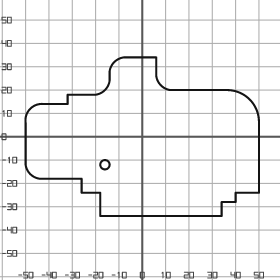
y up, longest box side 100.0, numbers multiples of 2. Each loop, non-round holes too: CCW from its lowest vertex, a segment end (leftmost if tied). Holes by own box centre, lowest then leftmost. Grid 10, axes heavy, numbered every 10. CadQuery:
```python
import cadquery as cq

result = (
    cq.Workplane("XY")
    .moveTo(-18.0, -34.0)
    .lineTo(34.0, -34.0)
    .lineTo(34.0, -28.0)
    .lineTo(40.0, -28.0)
    .lineTo(40.0, -24.0)
    .lineTo(50.0, -24.0)
    .lineTo(50.0, 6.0)
    .threePointArc((46.0, 16.0), (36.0, 20.0))
    .lineTo(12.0, 20.0)
    .threePointArc((8.0, 22.0), (6.0, 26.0))
    .lineTo(6.0, 34.0)
    .lineTo(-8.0, 34.0)
    .threePointArc((-12.0, 32.0), (-14.0, 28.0))
    .lineTo(-14.0, 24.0)
    .threePointArc((-16.0, 20.0), (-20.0, 18.0))
    .lineTo(-32.0, 18.0)
    .lineTo(-32.0, 14.0)
    .lineTo(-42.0, 14.0)
    .threePointArc((-48.0, 12.0), (-50.0, 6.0))
    .lineTo(-50.0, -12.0)
    .threePointArc((-48.0, -16.0), (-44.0, -18.0))
    .lineTo(-26.0, -18.0)
    .lineTo(-26.0, -24.0)
    .lineTo(-18.0, -24.0)
    .close()
    .moveTo(-16.0, -12.0)
    .circle(2.0)
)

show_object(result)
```